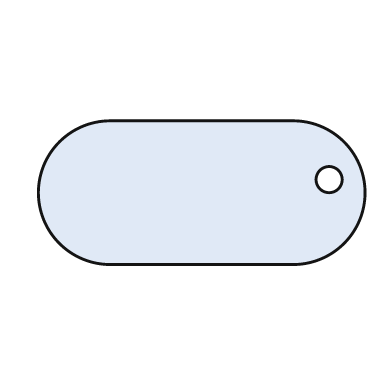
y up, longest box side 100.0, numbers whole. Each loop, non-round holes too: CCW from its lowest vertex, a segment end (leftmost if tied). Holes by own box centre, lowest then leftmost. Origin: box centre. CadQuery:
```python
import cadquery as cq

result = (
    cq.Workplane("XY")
    .moveTo(-28.0, -22.0)
    .lineTo(28.0, -22.0)
    .threePointArc((50.0, 0.0), (28.0, 22.0))
    .lineTo(-28.0, 22.0)
    .threePointArc((-50.0, 0.0), (-28.0, -22.0))
    .close()
    .moveTo(39.0, 4.0)
    .circle(4.0)
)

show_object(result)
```